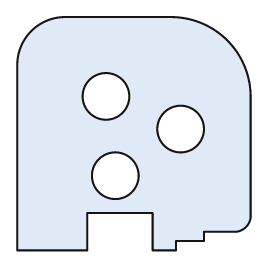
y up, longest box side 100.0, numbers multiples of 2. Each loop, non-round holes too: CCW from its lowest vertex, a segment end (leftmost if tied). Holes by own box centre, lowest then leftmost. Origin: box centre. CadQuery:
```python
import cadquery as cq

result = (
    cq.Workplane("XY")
    .moveTo(-50.0, -50.0)
    .lineTo(-20.0, -50.0)
    .lineTo(-20.0, -34.0)
    .lineTo(8.0, -34.0)
    .lineTo(8.0, -50.0)
    .lineTo(18.0, -50.0)
    .lineTo(18.0, -46.0)
    .lineTo(30.0, -46.0)
    .lineTo(30.0, -42.0)
    .lineTo(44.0, -42.0)
    .threePointArc((48.0, -40.0), (50.0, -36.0))
    .lineTo(50.0, 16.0)
    .threePointArc((40.0, 40.0), (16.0, 50.0))
    .lineTo(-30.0, 50.0)
    .threePointArc((-44.0, 44.0), (-50.0, 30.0))
    .close()
    .moveTo(-8.0, -18.0)
    .circle(10.0)
    .moveTo(20.0, 2.0)
    .circle(10.0)
    .moveTo(-12.0, 16.0)
    .circle(10.0)
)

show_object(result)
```